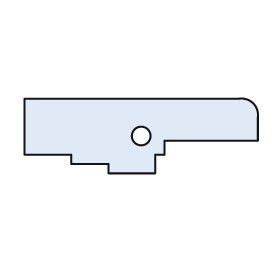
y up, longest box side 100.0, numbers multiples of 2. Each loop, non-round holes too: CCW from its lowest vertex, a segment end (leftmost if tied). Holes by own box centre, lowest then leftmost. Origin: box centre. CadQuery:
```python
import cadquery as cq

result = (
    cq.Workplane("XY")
    .moveTo(-14.0, -16.0)
    .lineTo(6.0, -16.0)
    .lineTo(6.0, -8.0)
    .lineTo(10.0, -8.0)
    .lineTo(10.0, -2.0)
    .lineTo(50.0, -2.0)
    .lineTo(50.0, 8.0)
    .threePointArc((48.0, 14.0), (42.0, 16.0))
    .lineTo(-50.0, 16.0)
    .lineTo(-50.0, -8.0)
    .lineTo(-30.0, -8.0)
    .lineTo(-30.0, -12.0)
    .lineTo(-14.0, -12.0)
    .close()
    .moveTo(0.0, 0.0)
    .circle(4.0)
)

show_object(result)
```